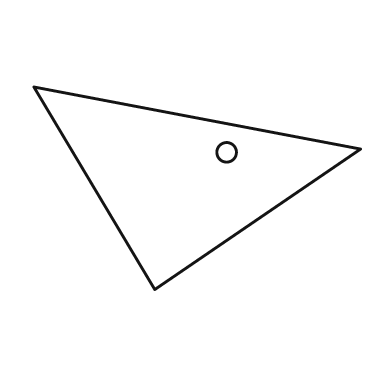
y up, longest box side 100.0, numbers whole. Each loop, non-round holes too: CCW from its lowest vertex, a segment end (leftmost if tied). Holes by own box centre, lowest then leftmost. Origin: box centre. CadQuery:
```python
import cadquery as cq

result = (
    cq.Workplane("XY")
    .moveTo(-13.0, -31.0)
    .lineTo(50.0, 12.0)
    .lineTo(-50.0, 31.0)
    .close()
    .moveTo(9.0, 11.0)
    .circle(3.0)
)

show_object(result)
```